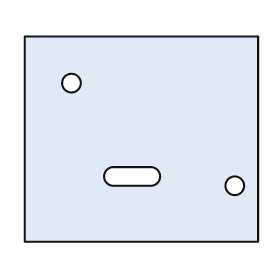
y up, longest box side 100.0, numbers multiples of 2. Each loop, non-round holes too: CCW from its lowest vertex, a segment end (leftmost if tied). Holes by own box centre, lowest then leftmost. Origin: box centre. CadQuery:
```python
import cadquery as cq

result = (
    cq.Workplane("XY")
    .moveTo(-50.0, -44.0)
    .lineTo(50.0, -44.0)
    .lineTo(50.0, 44.0)
    .lineTo(-50.0, 44.0)
    .close()
    .moveTo(40.0, -20.0)
    .circle(4.0)
    .moveTo(-12.0, -20.0)
    .lineTo(4.0, -20.0)
    .threePointArc((8.0, -16.0), (4.0, -12.0))
    .lineTo(-12.0, -12.0)
    .threePointArc((-16.0, -16.0), (-12.0, -20.0))
    .close()
    .moveTo(-30.0, 24.0)
    .circle(4.0)
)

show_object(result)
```